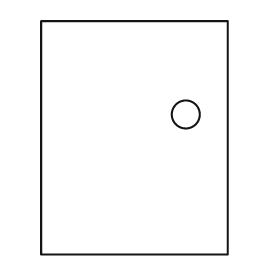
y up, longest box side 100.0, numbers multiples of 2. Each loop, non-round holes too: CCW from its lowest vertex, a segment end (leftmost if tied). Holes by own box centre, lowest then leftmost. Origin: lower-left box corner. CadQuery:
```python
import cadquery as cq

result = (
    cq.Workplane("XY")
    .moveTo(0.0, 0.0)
    .lineTo(80.0, 0.0)
    .lineTo(80.0, 100.0)
    .lineTo(0.0, 100.0)
    .close()
    .moveTo(62.0, 60.0)
    .circle(6.0)
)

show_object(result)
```